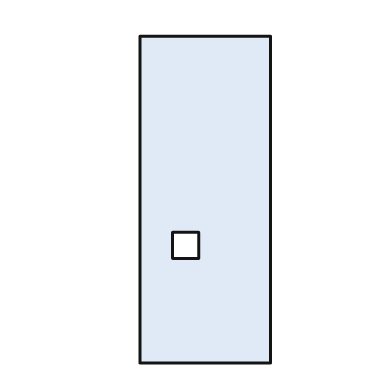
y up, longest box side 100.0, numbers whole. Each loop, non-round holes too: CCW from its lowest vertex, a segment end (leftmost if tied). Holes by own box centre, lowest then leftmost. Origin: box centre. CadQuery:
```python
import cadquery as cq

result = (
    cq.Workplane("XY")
    .moveTo(-20.0, -50.0)
    .lineTo(20.0, -50.0)
    .lineTo(20.0, 50.0)
    .lineTo(-20.0, 50.0)
    .close()
    .moveTo(-10.0, -18.0)
    .lineTo(-2.0, -18.0)
    .lineTo(-2.0, -10.0)
    .lineTo(-10.0, -10.0)
    .close()
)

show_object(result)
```